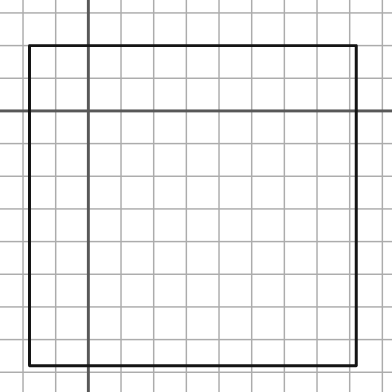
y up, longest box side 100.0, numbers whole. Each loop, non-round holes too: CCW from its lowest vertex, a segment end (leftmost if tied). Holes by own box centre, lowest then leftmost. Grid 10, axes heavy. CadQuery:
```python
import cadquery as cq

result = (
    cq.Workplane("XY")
    .moveTo(-18.0, -78.0)
    .lineTo(82.0, -78.0)
    .lineTo(82.0, 20.0)
    .lineTo(-18.0, 20.0)
    .close()
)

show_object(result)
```